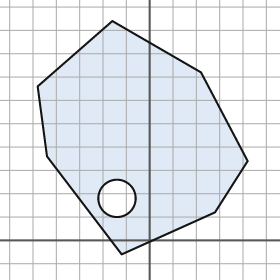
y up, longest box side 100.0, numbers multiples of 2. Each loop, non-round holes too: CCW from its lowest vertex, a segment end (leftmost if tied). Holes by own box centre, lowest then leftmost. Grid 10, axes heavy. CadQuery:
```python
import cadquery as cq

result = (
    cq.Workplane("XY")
    .moveTo(-12.0, -6.0)
    .lineTo(28.0, 12.0)
    .lineTo(42.0, 34.0)
    .lineTo(22.0, 72.0)
    .lineTo(-16.0, 94.0)
    .lineTo(-48.0, 66.0)
    .lineTo(-44.0, 36.0)
    .close()
    .moveTo(-14.0, 18.0)
    .circle(8.0)
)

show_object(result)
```